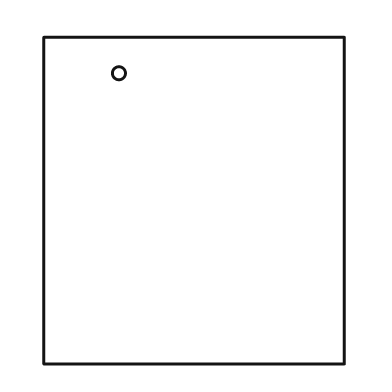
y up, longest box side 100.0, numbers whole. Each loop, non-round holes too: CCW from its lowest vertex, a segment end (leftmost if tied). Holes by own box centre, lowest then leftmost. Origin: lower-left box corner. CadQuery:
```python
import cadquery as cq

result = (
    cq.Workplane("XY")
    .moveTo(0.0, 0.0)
    .lineTo(92.0, 0.0)
    .lineTo(92.0, 100.0)
    .lineTo(0.0, 100.0)
    .close()
    .moveTo(23.0, 89.0)
    .circle(2.0)
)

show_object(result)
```